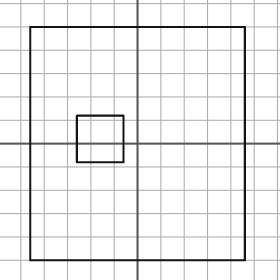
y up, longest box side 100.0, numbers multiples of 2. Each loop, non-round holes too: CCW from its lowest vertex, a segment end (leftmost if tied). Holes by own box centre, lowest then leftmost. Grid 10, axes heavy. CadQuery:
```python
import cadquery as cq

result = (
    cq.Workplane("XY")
    .moveTo(-46.0, -50.0)
    .lineTo(46.0, -50.0)
    .lineTo(46.0, 50.0)
    .lineTo(-46.0, 50.0)
    .close()
    .moveTo(-26.0, -8.0)
    .lineTo(-6.0, -8.0)
    .lineTo(-6.0, 12.0)
    .lineTo(-26.0, 12.0)
    .close()
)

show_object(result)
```